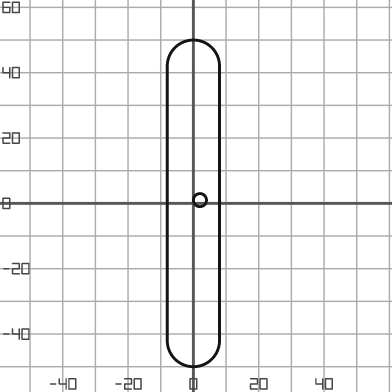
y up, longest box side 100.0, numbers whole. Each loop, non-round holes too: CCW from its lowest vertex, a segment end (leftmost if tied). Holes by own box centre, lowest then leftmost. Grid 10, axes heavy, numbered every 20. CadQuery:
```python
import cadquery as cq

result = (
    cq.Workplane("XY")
    .moveTo(-8.0, -42.0)
    .threePointArc((0.0, -50.0), (8.0, -42.0))
    .lineTo(8.0, 42.0)
    .threePointArc((0.0, 50.0), (-8.0, 42.0))
    .close()
    .moveTo(2.0, 1.0)
    .circle(2.0)
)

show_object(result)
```